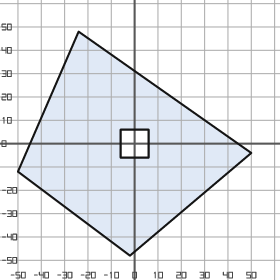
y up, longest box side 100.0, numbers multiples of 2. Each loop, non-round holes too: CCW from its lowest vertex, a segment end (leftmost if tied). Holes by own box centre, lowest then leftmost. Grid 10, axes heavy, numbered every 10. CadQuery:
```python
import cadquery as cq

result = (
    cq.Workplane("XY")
    .moveTo(-2.0, -48.0)
    .lineTo(50.0, -4.0)
    .lineTo(-24.0, 48.0)
    .lineTo(-50.0, -12.0)
    .close()
    .moveTo(-6.0, -6.0)
    .lineTo(6.0, -6.0)
    .lineTo(6.0, 6.0)
    .lineTo(-6.0, 6.0)
    .close()
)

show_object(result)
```